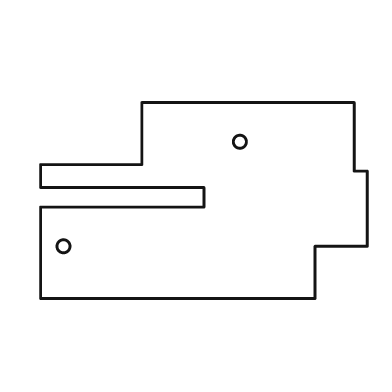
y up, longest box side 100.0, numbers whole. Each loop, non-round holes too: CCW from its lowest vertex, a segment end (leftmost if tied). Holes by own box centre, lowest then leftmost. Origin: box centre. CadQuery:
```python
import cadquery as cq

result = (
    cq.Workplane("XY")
    .moveTo(-50.0, -30.0)
    .lineTo(34.0, -30.0)
    .lineTo(34.0, -14.0)
    .lineTo(50.0, -14.0)
    .lineTo(50.0, 9.0)
    .lineTo(46.0, 9.0)
    .lineTo(46.0, 30.0)
    .lineTo(-19.0, 30.0)
    .lineTo(-19.0, 11.0)
    .lineTo(-50.0, 11.0)
    .lineTo(-50.0, 4.0)
    .lineTo(0.0, 4.0)
    .lineTo(0.0, -2.0)
    .lineTo(-50.0, -2.0)
    .close()
    .moveTo(-43.0, -14.0)
    .circle(2.0)
    .moveTo(11.0, 18.0)
    .circle(2.0)
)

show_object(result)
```